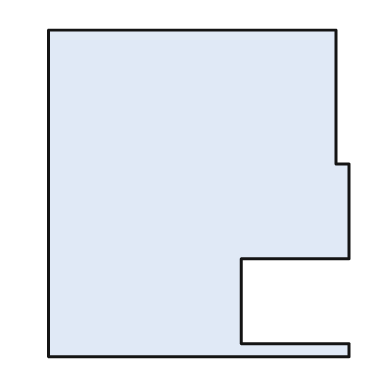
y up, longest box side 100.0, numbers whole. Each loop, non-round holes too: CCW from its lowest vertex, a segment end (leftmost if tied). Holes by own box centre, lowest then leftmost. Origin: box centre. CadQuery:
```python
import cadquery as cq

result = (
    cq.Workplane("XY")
    .moveTo(-46.0, -50.0)
    .lineTo(46.0, -50.0)
    .lineTo(46.0, -46.0)
    .lineTo(13.0, -46.0)
    .lineTo(13.0, -20.0)
    .lineTo(46.0, -20.0)
    .lineTo(46.0, 9.0)
    .lineTo(42.0, 9.0)
    .lineTo(42.0, 50.0)
    .lineTo(-46.0, 50.0)
    .close()
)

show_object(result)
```